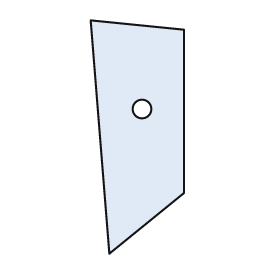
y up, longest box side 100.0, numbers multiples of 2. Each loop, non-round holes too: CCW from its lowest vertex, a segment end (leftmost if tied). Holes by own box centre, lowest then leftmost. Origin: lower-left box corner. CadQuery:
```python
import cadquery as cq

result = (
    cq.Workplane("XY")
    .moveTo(8.0, 0.0)
    .lineTo(40.0, 26.0)
    .lineTo(40.0, 96.0)
    .lineTo(0.0, 100.0)
    .close()
    .moveTo(22.0, 62.0)
    .circle(4.0)
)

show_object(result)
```